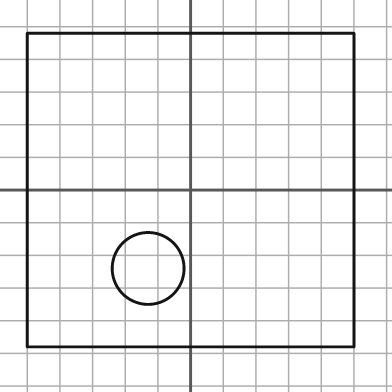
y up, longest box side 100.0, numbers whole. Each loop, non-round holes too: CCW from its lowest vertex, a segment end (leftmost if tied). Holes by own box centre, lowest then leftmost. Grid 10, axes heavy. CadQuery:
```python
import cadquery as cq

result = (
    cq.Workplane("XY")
    .moveTo(-50.0, -48.0)
    .lineTo(50.0, -48.0)
    .lineTo(50.0, 48.0)
    .lineTo(-50.0, 48.0)
    .close()
    .moveTo(-13.0, -24.0)
    .circle(11.0)
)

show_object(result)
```